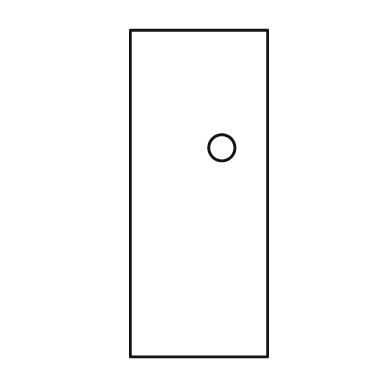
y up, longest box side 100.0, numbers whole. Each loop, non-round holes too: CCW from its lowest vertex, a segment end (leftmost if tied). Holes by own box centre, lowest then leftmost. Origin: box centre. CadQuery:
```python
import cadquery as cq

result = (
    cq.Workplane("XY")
    .moveTo(-21.0, -50.0)
    .lineTo(21.0, -50.0)
    .lineTo(21.0, 50.0)
    .lineTo(-21.0, 50.0)
    .close()
    .moveTo(7.0, 14.0)
    .circle(4.0)
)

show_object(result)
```